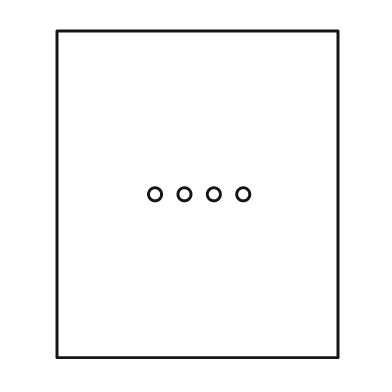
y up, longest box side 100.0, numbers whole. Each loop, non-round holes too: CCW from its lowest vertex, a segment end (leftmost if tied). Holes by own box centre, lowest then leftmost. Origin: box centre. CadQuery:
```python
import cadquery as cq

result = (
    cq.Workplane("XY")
    .moveTo(-43.0, -50.0)
    .lineTo(43.0, -50.0)
    .lineTo(43.0, 50.0)
    .lineTo(-43.0, 50.0)
    .close()
    .moveTo(-13.0, 0.0)
    .circle(2.0)
    .moveTo(-4.0, 0.0)
    .circle(2.0)
    .moveTo(5.0, 0.0)
    .circle(2.0)
    .moveTo(14.0, 0.0)
    .circle(2.0)
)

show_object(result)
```